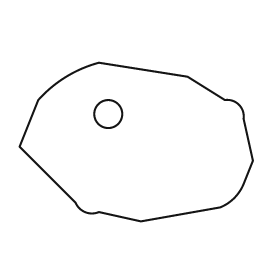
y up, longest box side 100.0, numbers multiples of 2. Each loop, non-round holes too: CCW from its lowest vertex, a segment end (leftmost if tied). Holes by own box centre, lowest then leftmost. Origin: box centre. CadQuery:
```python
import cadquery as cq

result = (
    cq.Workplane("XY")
    .moveTo(2.0, -34.0)
    .lineTo(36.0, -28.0)
    .threePointArc((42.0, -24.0), (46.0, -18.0))
    .lineTo(50.0, -8.0)
    .lineTo(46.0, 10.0)
    .threePointArc((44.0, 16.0), (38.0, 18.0))
    .lineTo(22.0, 28.0)
    .lineTo(-16.0, 34.0)
    .threePointArc((-30.0, 28.0), (-42.0, 18.0))
    .lineTo(-50.0, -2.0)
    .lineTo(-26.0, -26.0)
    .threePointArc((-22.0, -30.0), (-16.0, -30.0))
    .close()
    .moveTo(-12.0, 12.0)
    .circle(6.0)
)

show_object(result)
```